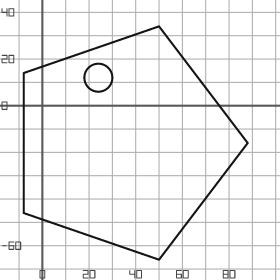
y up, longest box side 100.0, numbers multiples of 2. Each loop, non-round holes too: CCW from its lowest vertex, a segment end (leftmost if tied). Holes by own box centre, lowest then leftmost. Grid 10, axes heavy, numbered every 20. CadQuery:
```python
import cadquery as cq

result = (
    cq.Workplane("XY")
    .moveTo(50.0, -66.0)
    .lineTo(88.0, -16.0)
    .lineTo(50.0, 34.0)
    .lineTo(-8.0, 14.0)
    .lineTo(-8.0, -46.0)
    .close()
    .moveTo(24.0, 12.0)
    .circle(6.0)
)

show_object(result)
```